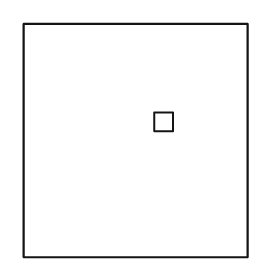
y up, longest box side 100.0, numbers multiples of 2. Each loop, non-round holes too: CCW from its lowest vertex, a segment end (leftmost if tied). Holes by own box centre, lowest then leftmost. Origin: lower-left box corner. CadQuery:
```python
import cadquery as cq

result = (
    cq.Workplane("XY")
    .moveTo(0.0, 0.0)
    .lineTo(96.0, 0.0)
    .lineTo(96.0, 100.0)
    .lineTo(0.0, 100.0)
    .close()
    .moveTo(56.0, 54.0)
    .lineTo(64.0, 54.0)
    .lineTo(64.0, 62.0)
    .lineTo(56.0, 62.0)
    .close()
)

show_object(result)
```